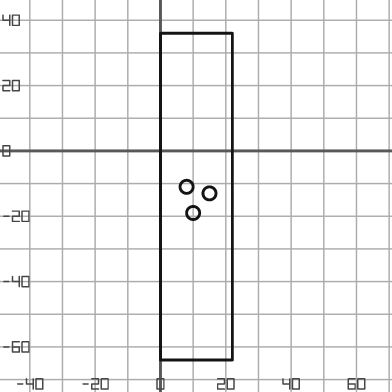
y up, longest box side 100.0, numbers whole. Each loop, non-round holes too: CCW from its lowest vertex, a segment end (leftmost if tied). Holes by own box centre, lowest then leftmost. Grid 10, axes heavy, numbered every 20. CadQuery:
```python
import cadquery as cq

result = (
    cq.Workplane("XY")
    .moveTo(0.0, -64.0)
    .lineTo(22.0, -64.0)
    .lineTo(22.0, 36.0)
    .lineTo(0.0, 36.0)
    .close()
    .moveTo(10.0, -19.0)
    .circle(2.0)
    .moveTo(15.0, -13.0)
    .circle(2.0)
    .moveTo(8.0, -11.0)
    .circle(2.0)
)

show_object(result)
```